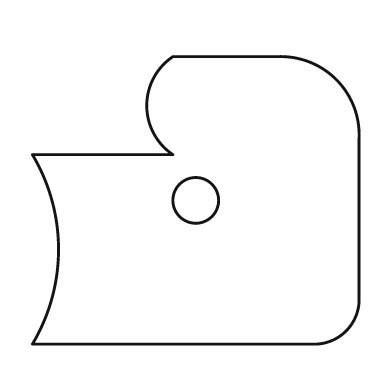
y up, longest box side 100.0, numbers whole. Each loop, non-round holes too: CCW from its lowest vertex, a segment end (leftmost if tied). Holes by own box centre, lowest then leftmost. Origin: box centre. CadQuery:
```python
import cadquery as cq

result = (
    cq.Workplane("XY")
    .moveTo(-50.0, -44.0)
    .lineTo(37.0, -44.0)
    .threePointArc((46.0, -40.0), (50.0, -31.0))
    .lineTo(50.0, 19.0)
    .threePointArc((43.0, 37.0), (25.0, 44.0))
    .lineTo(-7.0, 44.0)
    .threePointArc((-15.0, 29.0), (-7.0, 14.0))
    .lineTo(-50.0, 14.0)
    .threePointArc((-42.0, -15.0), (-50.0, -44.0))
    .close()
    .moveTo(0.0, 0.0)
    .circle(7.0)
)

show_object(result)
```